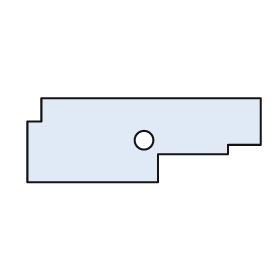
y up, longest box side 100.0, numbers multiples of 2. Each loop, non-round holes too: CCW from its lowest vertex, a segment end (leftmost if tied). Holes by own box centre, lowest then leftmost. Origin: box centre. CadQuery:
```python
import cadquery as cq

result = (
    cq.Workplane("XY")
    .moveTo(-50.0, -18.0)
    .lineTo(6.0, -18.0)
    .lineTo(6.0, -6.0)
    .lineTo(36.0, -6.0)
    .lineTo(36.0, -2.0)
    .lineTo(50.0, -2.0)
    .lineTo(50.0, 18.0)
    .lineTo(-44.0, 18.0)
    .lineTo(-44.0, 8.0)
    .lineTo(-50.0, 8.0)
    .close()
    .moveTo(0.0, 0.0)
    .circle(4.0)
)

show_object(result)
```